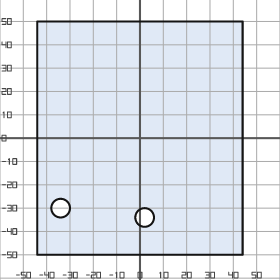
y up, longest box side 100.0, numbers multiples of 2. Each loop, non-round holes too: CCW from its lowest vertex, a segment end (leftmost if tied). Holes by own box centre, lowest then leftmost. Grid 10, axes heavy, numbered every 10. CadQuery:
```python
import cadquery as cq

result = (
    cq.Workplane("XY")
    .moveTo(-44.0, -50.0)
    .lineTo(44.0, -50.0)
    .lineTo(44.0, 50.0)
    .lineTo(-44.0, 50.0)
    .close()
    .moveTo(2.0, -34.0)
    .circle(4.0)
    .moveTo(-34.0, -30.0)
    .circle(4.0)
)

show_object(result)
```